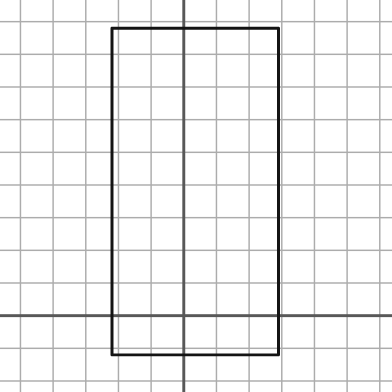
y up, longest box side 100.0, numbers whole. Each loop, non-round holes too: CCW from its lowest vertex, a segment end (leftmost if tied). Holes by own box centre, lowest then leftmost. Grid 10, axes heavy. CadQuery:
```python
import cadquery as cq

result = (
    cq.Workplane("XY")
    .moveTo(-22.0, -12.0)
    .lineTo(29.0, -12.0)
    .lineTo(29.0, 88.0)
    .lineTo(-22.0, 88.0)
    .close()
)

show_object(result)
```